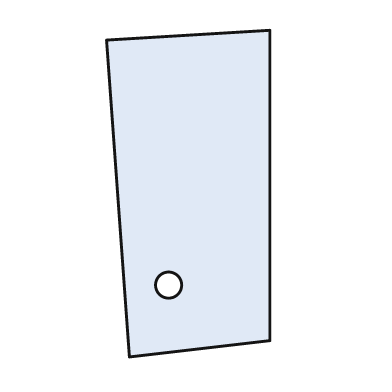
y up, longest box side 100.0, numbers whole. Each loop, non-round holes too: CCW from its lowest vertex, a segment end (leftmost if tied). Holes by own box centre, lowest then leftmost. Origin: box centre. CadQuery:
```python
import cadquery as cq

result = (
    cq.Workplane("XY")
    .moveTo(-18.0, -50.0)
    .lineTo(25.0, -45.0)
    .lineTo(25.0, 50.0)
    .lineTo(-25.0, 47.0)
    .close()
    .moveTo(-6.0, -28.0)
    .circle(4.0)
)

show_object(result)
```